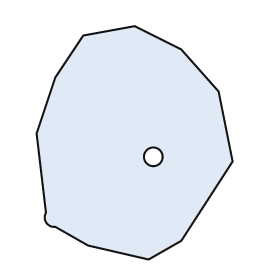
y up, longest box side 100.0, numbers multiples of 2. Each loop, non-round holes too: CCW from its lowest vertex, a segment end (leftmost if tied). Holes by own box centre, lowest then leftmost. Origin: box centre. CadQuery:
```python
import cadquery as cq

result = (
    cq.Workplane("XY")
    .moveTo(6.0, -50.0)
    .lineTo(20.0, -42.0)
    .lineTo(42.0, -8.0)
    .lineTo(36.0, 22.0)
    .lineTo(20.0, 40.0)
    .lineTo(0.0, 50.0)
    .lineTo(-22.0, 46.0)
    .lineTo(-34.0, 28.0)
    .lineTo(-42.0, 4.0)
    .lineTo(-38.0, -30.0)
    .threePointArc((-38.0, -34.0), (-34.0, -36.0))
    .lineTo(-20.0, -44.0)
    .close()
    .moveTo(8.0, -6.0)
    .circle(4.0)
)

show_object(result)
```